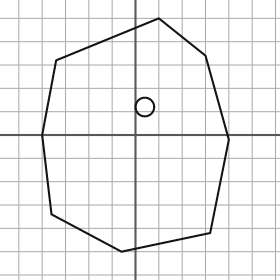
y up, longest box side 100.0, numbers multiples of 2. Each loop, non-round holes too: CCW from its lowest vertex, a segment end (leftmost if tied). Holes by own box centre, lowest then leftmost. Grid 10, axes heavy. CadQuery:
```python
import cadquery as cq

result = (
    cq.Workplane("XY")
    .moveTo(-6.0, -50.0)
    .lineTo(32.0, -42.0)
    .lineTo(40.0, -2.0)
    .lineTo(30.0, 34.0)
    .lineTo(10.0, 50.0)
    .lineTo(-34.0, 32.0)
    .lineTo(-40.0, 0.0)
    .lineTo(-36.0, -34.0)
    .close()
    .moveTo(4.0, 12.0)
    .circle(4.0)
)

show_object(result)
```